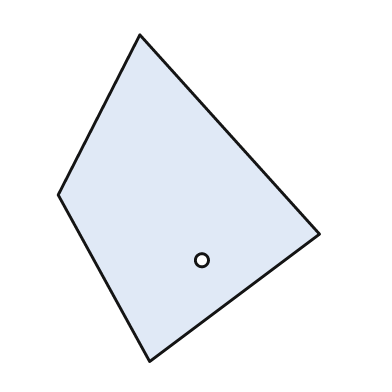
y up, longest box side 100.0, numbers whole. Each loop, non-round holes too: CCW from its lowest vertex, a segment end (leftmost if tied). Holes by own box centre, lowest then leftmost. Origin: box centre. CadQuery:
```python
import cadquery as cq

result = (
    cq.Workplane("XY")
    .moveTo(-12.0, -50.0)
    .lineTo(40.0, -11.0)
    .lineTo(-15.0, 50.0)
    .lineTo(-40.0, 1.0)
    .close()
    .moveTo(4.0, -19.0)
    .circle(2.0)
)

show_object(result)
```